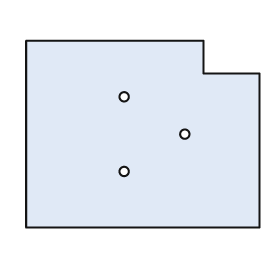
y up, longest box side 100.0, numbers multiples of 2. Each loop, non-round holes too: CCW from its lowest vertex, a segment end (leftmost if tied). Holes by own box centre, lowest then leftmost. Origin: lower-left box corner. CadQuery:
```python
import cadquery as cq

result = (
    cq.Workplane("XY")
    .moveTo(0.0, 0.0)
    .lineTo(100.0, 0.0)
    .lineTo(100.0, 66.0)
    .lineTo(76.0, 66.0)
    .lineTo(76.0, 80.0)
    .lineTo(0.0, 80.0)
    .close()
    .moveTo(42.0, 24.0)
    .circle(2.0)
    .moveTo(68.0, 40.0)
    .circle(2.0)
    .moveTo(42.0, 56.0)
    .circle(2.0)
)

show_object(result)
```